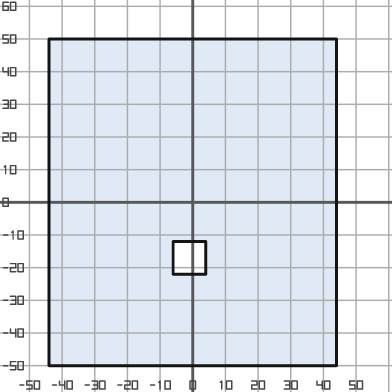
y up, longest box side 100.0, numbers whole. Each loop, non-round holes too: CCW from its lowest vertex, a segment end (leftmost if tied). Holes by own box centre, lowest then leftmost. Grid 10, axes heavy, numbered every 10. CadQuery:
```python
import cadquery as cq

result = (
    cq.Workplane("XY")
    .moveTo(-44.0, -50.0)
    .lineTo(44.0, -50.0)
    .lineTo(44.0, 50.0)
    .lineTo(-44.0, 50.0)
    .close()
    .moveTo(-6.0, -22.0)
    .lineTo(4.0, -22.0)
    .lineTo(4.0, -12.0)
    .lineTo(-6.0, -12.0)
    .close()
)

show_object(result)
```